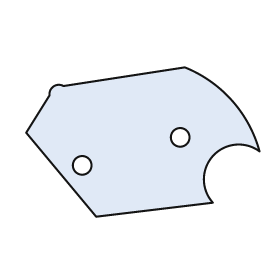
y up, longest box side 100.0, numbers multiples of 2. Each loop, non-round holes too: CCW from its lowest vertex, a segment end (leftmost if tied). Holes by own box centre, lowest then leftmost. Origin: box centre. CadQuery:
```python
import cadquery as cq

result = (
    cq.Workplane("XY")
    .moveTo(-20.0, -32.0)
    .lineTo(30.0, -26.0)
    .threePointArc((30.0, -6.0), (50.0, -4.0))
    .threePointArc((38.0, 18.0), (18.0, 32.0))
    .lineTo(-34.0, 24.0)
    .threePointArc((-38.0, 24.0), (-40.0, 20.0))
    .lineTo(-50.0, 4.0)
    .close()
    .moveTo(-26.0, -10.0)
    .circle(4.0)
    .moveTo(16.0, 2.0)
    .circle(4.0)
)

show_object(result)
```